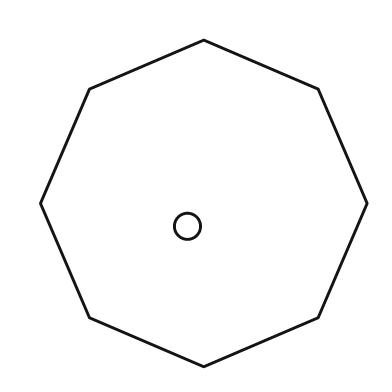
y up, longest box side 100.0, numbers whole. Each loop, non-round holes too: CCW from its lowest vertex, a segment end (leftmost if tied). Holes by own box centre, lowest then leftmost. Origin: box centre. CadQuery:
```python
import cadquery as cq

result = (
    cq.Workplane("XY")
    .moveTo(0.0, -50.0)
    .lineTo(35.0, -35.0)
    .lineTo(50.0, 0.0)
    .lineTo(35.0, 35.0)
    .lineTo(0.0, 50.0)
    .lineTo(-35.0, 35.0)
    .lineTo(-50.0, 0.0)
    .lineTo(-35.0, -35.0)
    .close()
    .moveTo(-5.0, -7.0)
    .circle(4.0)
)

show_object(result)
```